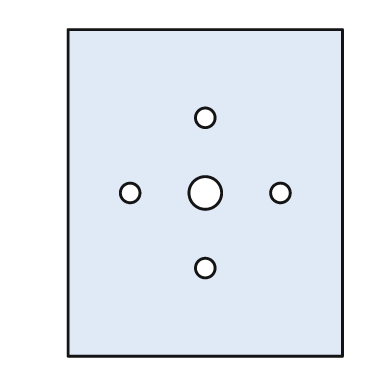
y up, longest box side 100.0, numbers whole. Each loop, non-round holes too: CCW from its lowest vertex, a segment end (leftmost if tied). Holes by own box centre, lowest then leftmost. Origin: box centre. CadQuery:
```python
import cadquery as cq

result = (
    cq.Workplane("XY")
    .moveTo(-42.0, -50.0)
    .lineTo(42.0, -50.0)
    .lineTo(42.0, 50.0)
    .lineTo(-42.0, 50.0)
    .close()
    .moveTo(0.0, -23.0)
    .circle(3.0)
    .moveTo(-23.0, 0.0)
    .circle(3.0)
    .moveTo(0.0, 0.0)
    .circle(5.0)
    .moveTo(23.0, 0.0)
    .circle(3.0)
    .moveTo(0.0, 23.0)
    .circle(3.0)
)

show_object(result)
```